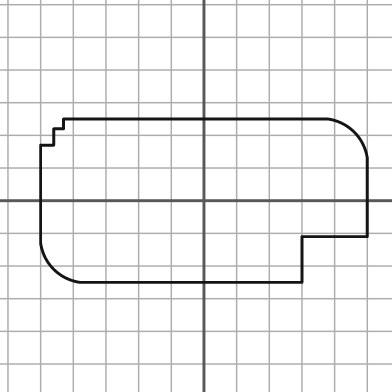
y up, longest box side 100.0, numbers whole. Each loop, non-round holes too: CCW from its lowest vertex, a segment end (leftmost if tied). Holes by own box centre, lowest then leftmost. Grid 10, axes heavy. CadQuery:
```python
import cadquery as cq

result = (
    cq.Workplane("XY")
    .moveTo(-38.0, -25.0)
    .lineTo(30.0, -25.0)
    .lineTo(30.0, -11.0)
    .lineTo(50.0, -11.0)
    .lineTo(50.0, 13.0)
    .threePointArc((46.0, 21.0), (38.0, 25.0))
    .lineTo(-43.0, 25.0)
    .lineTo(-43.0, 22.0)
    .lineTo(-46.0, 22.0)
    .lineTo(-46.0, 17.0)
    .lineTo(-50.0, 17.0)
    .lineTo(-50.0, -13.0)
    .threePointArc((-46.0, -21.0), (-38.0, -25.0))
    .close()
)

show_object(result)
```